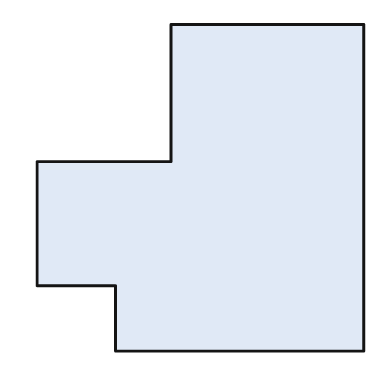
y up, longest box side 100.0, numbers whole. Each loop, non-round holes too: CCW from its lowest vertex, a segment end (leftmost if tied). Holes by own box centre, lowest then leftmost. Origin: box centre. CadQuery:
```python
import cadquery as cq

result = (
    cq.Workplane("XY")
    .moveTo(-26.0, -50.0)
    .lineTo(50.0, -50.0)
    .lineTo(50.0, 50.0)
    .lineTo(-9.0, 50.0)
    .lineTo(-9.0, 8.0)
    .lineTo(-50.0, 8.0)
    .lineTo(-50.0, -30.0)
    .lineTo(-26.0, -30.0)
    .close()
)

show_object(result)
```